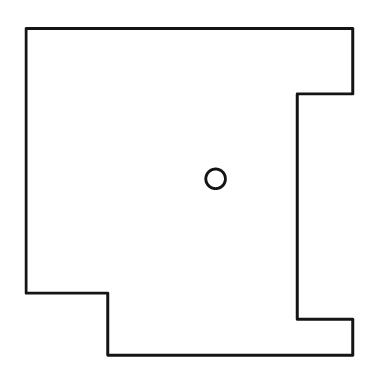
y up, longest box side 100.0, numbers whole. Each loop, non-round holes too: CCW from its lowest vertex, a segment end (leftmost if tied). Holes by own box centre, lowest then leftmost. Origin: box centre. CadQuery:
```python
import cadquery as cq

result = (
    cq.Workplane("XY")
    .moveTo(-25.0, -50.0)
    .lineTo(50.0, -50.0)
    .lineTo(50.0, -39.0)
    .lineTo(33.0, -39.0)
    .lineTo(33.0, 30.0)
    .lineTo(50.0, 30.0)
    .lineTo(50.0, 50.0)
    .lineTo(-50.0, 50.0)
    .lineTo(-50.0, -31.0)
    .lineTo(-25.0, -31.0)
    .close()
    .moveTo(8.0, 4.0)
    .circle(3.0)
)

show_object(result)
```